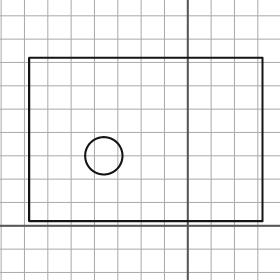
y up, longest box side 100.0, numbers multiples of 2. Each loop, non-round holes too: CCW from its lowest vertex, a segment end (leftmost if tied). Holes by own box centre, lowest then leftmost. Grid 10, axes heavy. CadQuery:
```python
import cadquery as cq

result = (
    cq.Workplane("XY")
    .moveTo(-68.0, 2.0)
    .lineTo(32.0, 2.0)
    .lineTo(32.0, 72.0)
    .lineTo(-68.0, 72.0)
    .close()
    .moveTo(-36.0, 30.0)
    .circle(8.0)
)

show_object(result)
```